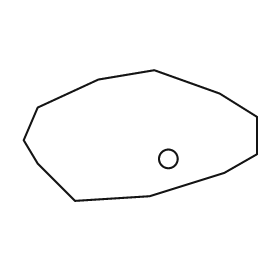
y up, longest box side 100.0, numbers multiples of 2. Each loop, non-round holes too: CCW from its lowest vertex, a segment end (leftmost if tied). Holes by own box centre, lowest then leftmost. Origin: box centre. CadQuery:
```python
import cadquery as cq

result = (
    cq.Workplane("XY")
    .moveTo(-28.0, -28.0)
    .lineTo(4.0, -26.0)
    .lineTo(36.0, -16.0)
    .lineTo(50.0, -8.0)
    .lineTo(50.0, 8.0)
    .lineTo(34.0, 18.0)
    .lineTo(6.0, 28.0)
    .lineTo(-18.0, 24.0)
    .lineTo(-44.0, 12.0)
    .lineTo(-50.0, -2.0)
    .lineTo(-44.0, -12.0)
    .close()
    .moveTo(12.0, -10.0)
    .circle(4.0)
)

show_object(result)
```